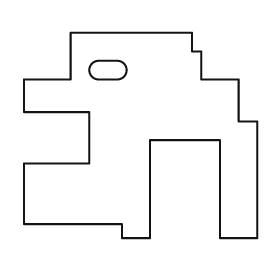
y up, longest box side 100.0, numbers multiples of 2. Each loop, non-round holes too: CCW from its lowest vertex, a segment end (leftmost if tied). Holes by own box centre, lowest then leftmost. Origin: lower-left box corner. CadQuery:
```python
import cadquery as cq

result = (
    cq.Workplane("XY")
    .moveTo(42.0, 0.0)
    .lineTo(54.0, 0.0)
    .lineTo(54.0, 42.0)
    .lineTo(84.0, 42.0)
    .lineTo(84.0, 0.0)
    .lineTo(100.0, 0.0)
    .lineTo(100.0, 50.0)
    .lineTo(92.0, 50.0)
    .lineTo(92.0, 68.0)
    .lineTo(76.0, 68.0)
    .lineTo(76.0, 80.0)
    .lineTo(72.0, 80.0)
    .lineTo(72.0, 88.0)
    .lineTo(20.0, 88.0)
    .lineTo(20.0, 68.0)
    .lineTo(0.0, 68.0)
    .lineTo(0.0, 54.0)
    .lineTo(28.0, 54.0)
    .lineTo(28.0, 32.0)
    .lineTo(0.0, 32.0)
    .lineTo(0.0, 6.0)
    .lineTo(42.0, 6.0)
    .close()
    .moveTo(32.0, 68.0)
    .lineTo(40.0, 68.0)
    .threePointArc((44.0, 72.0), (40.0, 76.0))
    .lineTo(32.0, 76.0)
    .threePointArc((28.0, 72.0), (32.0, 68.0))
    .close()
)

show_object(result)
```